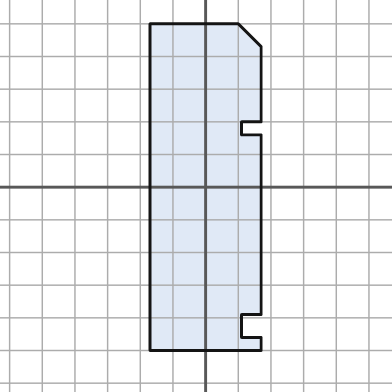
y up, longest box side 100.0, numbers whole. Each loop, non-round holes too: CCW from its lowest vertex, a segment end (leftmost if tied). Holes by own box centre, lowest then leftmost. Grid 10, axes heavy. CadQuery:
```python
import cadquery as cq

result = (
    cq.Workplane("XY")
    .moveTo(-17.0, -50.0)
    .lineTo(17.0, -50.0)
    .lineTo(17.0, -46.0)
    .lineTo(11.0, -46.0)
    .lineTo(11.0, -39.0)
    .lineTo(17.0, -39.0)
    .lineTo(17.0, 16.0)
    .lineTo(11.0, 16.0)
    .lineTo(11.0, 20.0)
    .lineTo(17.0, 20.0)
    .lineTo(17.0, 43.0)
    .lineTo(10.0, 50.0)
    .lineTo(-17.0, 50.0)
    .close()
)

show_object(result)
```